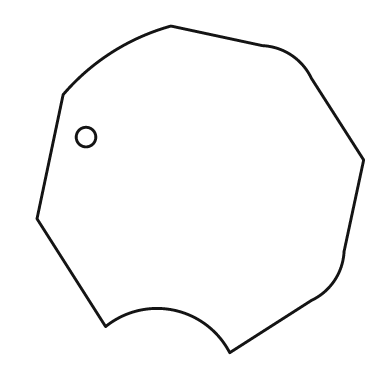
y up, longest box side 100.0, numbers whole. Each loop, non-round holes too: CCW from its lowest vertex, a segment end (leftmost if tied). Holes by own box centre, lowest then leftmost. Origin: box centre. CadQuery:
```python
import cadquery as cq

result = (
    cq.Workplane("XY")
    .moveTo(9.0, -50.0)
    .lineTo(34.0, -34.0)
    .threePointArc((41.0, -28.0), (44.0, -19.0))
    .lineTo(50.0, 9.0)
    .lineTo(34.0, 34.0)
    .threePointArc((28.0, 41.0), (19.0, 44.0))
    .lineTo(-9.0, 50.0)
    .threePointArc((-27.0, 42.0), (-42.0, 29.0))
    .lineTo(-50.0, -9.0)
    .lineTo(-29.0, -42.0)
    .threePointArc((-8.0, -37.0), (9.0, -50.0))
    .close()
    .moveTo(-35.0, 16.0)
    .circle(3.0)
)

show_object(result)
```